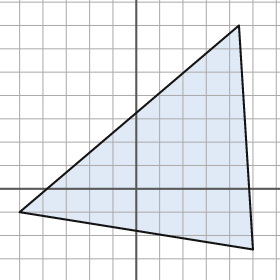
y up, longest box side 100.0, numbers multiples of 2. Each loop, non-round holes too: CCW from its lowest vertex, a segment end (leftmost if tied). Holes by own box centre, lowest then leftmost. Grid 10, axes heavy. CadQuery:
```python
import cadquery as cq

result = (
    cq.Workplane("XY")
    .moveTo(50.0, -26.0)
    .lineTo(44.0, 70.0)
    .lineTo(-50.0, -10.0)
    .close()
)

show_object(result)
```